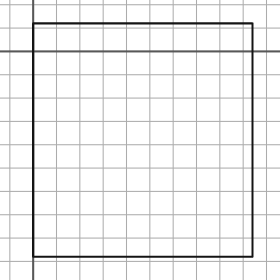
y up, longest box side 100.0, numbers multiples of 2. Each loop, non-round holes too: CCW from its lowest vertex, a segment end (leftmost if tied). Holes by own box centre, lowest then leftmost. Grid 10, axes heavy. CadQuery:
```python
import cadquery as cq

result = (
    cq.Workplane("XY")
    .moveTo(0.0, -88.0)
    .lineTo(94.0, -88.0)
    .lineTo(94.0, 12.0)
    .lineTo(0.0, 12.0)
    .close()
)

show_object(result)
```